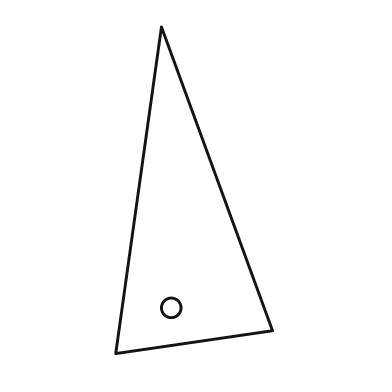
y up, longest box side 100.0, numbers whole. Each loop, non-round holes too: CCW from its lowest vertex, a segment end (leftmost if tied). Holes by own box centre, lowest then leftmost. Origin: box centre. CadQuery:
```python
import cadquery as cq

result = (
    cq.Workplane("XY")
    .moveTo(-24.0, -50.0)
    .lineTo(24.0, -43.0)
    .lineTo(-10.0, 50.0)
    .close()
    .moveTo(-7.0, -36.0)
    .circle(3.0)
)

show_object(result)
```